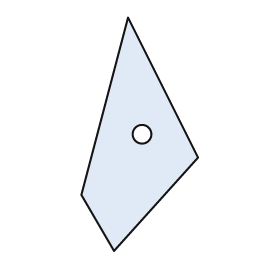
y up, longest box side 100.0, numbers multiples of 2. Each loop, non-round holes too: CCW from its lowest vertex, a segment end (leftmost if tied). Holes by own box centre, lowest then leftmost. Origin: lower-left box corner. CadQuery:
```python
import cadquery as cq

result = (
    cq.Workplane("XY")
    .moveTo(14.0, 0.0)
    .lineTo(50.0, 40.0)
    .lineTo(20.0, 100.0)
    .lineTo(0.0, 24.0)
    .close()
    .moveTo(26.0, 50.0)
    .circle(4.0)
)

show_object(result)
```